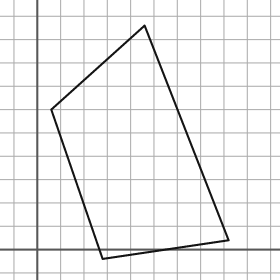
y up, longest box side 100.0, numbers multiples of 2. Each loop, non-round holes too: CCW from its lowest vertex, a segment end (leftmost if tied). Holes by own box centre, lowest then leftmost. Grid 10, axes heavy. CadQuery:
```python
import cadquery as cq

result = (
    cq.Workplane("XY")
    .moveTo(28.0, -4.0)
    .lineTo(82.0, 4.0)
    .lineTo(46.0, 96.0)
    .lineTo(6.0, 60.0)
    .close()
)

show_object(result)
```